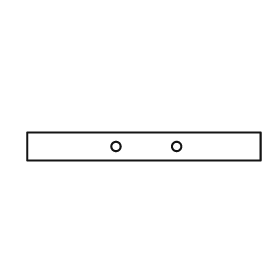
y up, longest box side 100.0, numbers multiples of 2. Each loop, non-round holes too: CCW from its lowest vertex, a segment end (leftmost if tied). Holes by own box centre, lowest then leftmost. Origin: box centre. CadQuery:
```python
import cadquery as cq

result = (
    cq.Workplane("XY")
    .moveTo(-50.0, -6.0)
    .lineTo(50.0, -6.0)
    .lineTo(50.0, 6.0)
    .lineTo(-50.0, 6.0)
    .close()
    .moveTo(-12.0, 0.0)
    .circle(2.0)
    .moveTo(14.0, 0.0)
    .circle(2.0)
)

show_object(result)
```